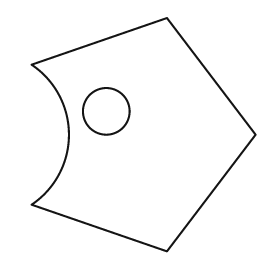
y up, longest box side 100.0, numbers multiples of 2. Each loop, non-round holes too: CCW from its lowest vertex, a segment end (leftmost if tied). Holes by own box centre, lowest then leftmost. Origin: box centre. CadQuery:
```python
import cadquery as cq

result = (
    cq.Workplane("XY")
    .moveTo(10.0, -50.0)
    .lineTo(48.0, 0.0)
    .lineTo(10.0, 50.0)
    .lineTo(-48.0, 30.0)
    .threePointArc((-32.0, 0.0), (-48.0, -30.0))
    .close()
    .moveTo(-16.0, 10.0)
    .circle(10.0)
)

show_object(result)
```